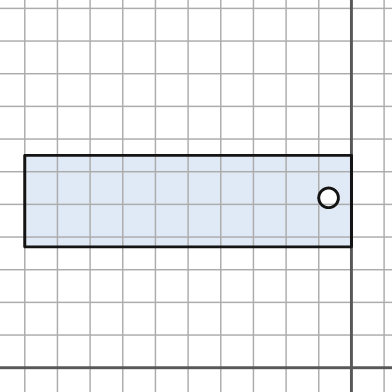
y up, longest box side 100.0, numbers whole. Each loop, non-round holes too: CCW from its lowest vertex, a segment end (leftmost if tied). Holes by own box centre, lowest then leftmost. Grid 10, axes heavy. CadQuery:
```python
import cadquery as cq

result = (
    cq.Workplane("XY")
    .moveTo(-100.0, 37.0)
    .lineTo(0.0, 37.0)
    .lineTo(0.0, 65.0)
    .lineTo(-100.0, 65.0)
    .close()
    .moveTo(-7.0, 52.0)
    .circle(3.0)
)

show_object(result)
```